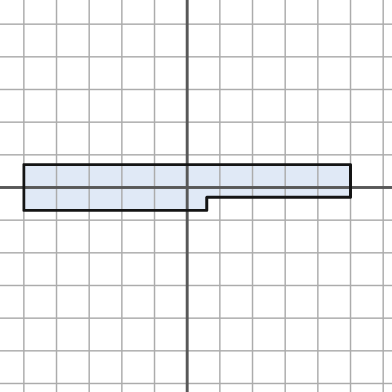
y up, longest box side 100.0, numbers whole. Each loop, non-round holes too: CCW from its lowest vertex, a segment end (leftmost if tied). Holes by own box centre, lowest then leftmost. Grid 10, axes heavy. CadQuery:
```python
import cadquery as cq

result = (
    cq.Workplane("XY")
    .moveTo(-50.0, -7.0)
    .lineTo(6.0, -7.0)
    .lineTo(6.0, -3.0)
    .lineTo(50.0, -3.0)
    .lineTo(50.0, 7.0)
    .lineTo(-50.0, 7.0)
    .close()
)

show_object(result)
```